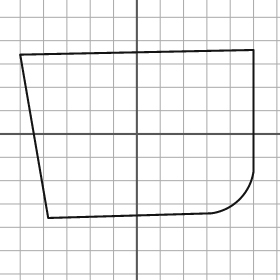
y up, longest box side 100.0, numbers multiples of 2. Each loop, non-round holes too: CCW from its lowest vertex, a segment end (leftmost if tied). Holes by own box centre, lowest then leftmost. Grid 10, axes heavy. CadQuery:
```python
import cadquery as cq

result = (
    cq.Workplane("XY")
    .moveTo(-38.0, -36.0)
    .lineTo(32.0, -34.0)
    .threePointArc((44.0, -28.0), (50.0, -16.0))
    .lineTo(50.0, 36.0)
    .lineTo(-50.0, 34.0)
    .close()
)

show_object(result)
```